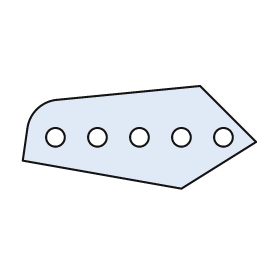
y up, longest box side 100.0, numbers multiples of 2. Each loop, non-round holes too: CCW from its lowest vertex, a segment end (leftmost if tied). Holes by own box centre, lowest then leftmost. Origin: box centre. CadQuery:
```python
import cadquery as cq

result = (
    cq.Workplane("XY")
    .moveTo(18.0, -22.0)
    .lineTo(50.0, -2.0)
    .lineTo(26.0, 22.0)
    .lineTo(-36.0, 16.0)
    .threePointArc((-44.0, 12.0), (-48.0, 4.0))
    .lineTo(-50.0, -10.0)
    .close()
    .moveTo(-36.0, 0.0)
    .circle(4.0)
    .moveTo(-18.0, 0.0)
    .circle(4.0)
    .moveTo(0.0, 0.0)
    .circle(4.0)
    .moveTo(18.0, 0.0)
    .circle(4.0)
    .moveTo(36.0, 0.0)
    .circle(4.0)
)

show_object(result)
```